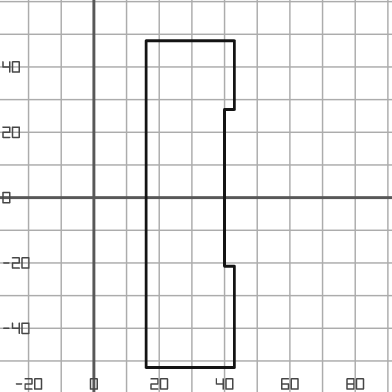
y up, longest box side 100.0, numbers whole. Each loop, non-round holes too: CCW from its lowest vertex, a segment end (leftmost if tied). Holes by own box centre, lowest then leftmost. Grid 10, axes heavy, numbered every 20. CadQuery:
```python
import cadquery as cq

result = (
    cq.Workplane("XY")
    .moveTo(16.0, -52.0)
    .lineTo(43.0, -52.0)
    .lineTo(43.0, -21.0)
    .lineTo(40.0, -21.0)
    .lineTo(40.0, 27.0)
    .lineTo(43.0, 27.0)
    .lineTo(43.0, 48.0)
    .lineTo(16.0, 48.0)
    .close()
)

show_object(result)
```